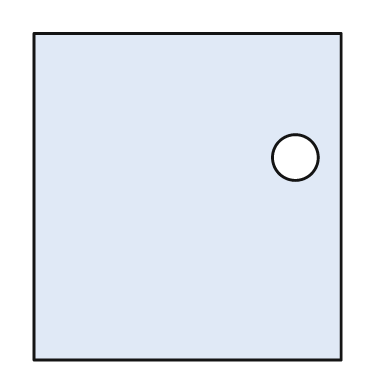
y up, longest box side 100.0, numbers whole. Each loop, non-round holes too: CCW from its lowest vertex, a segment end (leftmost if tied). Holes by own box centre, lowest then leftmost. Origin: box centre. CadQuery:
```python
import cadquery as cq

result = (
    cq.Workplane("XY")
    .moveTo(-47.0, -50.0)
    .lineTo(47.0, -50.0)
    .lineTo(47.0, 50.0)
    .lineTo(-47.0, 50.0)
    .close()
    .moveTo(33.0, 12.0)
    .circle(7.0)
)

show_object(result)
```